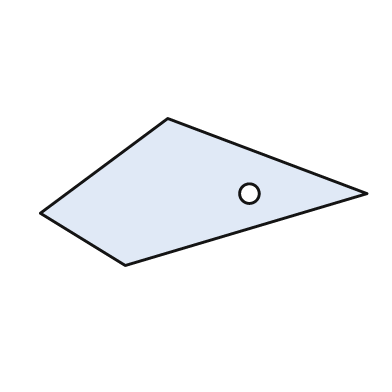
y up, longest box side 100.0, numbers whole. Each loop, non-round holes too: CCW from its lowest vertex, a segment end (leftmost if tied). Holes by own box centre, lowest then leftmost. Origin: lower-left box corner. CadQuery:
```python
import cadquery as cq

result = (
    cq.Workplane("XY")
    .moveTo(26.0, 0.0)
    .lineTo(100.0, 22.0)
    .lineTo(39.0, 45.0)
    .lineTo(0.0, 16.0)
    .close()
    .moveTo(64.0, 22.0)
    .circle(3.0)
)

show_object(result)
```